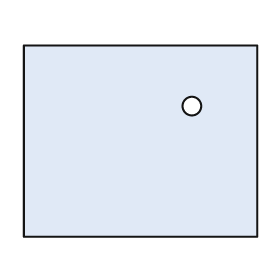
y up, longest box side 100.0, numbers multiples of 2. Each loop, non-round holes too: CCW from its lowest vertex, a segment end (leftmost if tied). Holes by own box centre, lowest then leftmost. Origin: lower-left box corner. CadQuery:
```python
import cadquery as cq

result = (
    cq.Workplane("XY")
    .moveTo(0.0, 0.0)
    .lineTo(100.0, 0.0)
    .lineTo(100.0, 82.0)
    .lineTo(0.0, 82.0)
    .close()
    .moveTo(72.0, 56.0)
    .circle(4.0)
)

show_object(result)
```